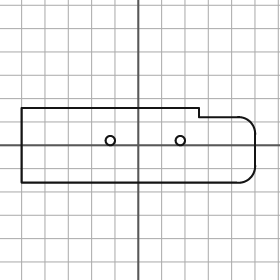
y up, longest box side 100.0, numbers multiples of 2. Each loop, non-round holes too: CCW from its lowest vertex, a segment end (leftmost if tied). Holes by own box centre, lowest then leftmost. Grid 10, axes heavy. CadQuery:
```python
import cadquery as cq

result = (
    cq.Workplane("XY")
    .moveTo(-50.0, -16.0)
    .lineTo(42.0, -16.0)
    .threePointArc((48.0, -14.0), (50.0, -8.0))
    .lineTo(50.0, 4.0)
    .threePointArc((48.0, 10.0), (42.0, 12.0))
    .lineTo(26.0, 12.0)
    .lineTo(26.0, 16.0)
    .lineTo(-50.0, 16.0)
    .close()
    .moveTo(-12.0, 2.0)
    .circle(2.0)
    .moveTo(18.0, 2.0)
    .circle(2.0)
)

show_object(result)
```